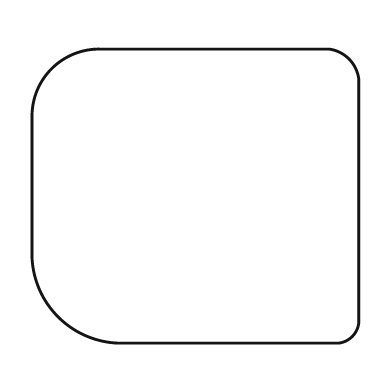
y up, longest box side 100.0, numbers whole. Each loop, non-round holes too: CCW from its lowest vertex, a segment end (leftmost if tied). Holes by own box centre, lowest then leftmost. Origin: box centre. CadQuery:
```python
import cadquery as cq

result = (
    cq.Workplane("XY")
    .moveTo(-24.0, -45.0)
    .lineTo(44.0, -45.0)
    .threePointArc((48.0, -43.0), (50.0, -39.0))
    .lineTo(50.0, 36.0)
    .threePointArc((47.0, 42.0), (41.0, 45.0))
    .lineTo(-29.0, 45.0)
    .threePointArc((-44.0, 39.0), (-50.0, 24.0))
    .lineTo(-50.0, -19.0)
    .threePointArc((-42.0, -37.0), (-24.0, -45.0))
    .close()
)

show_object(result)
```